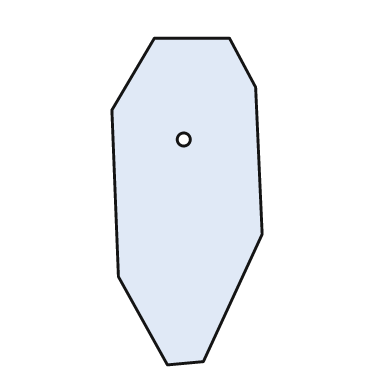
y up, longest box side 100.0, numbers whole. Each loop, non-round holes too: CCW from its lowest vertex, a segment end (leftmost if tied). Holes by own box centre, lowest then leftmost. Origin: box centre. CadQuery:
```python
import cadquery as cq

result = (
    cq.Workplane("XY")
    .moveTo(-6.0, -50.0)
    .lineTo(5.0, -49.0)
    .lineTo(23.0, -10.0)
    .lineTo(21.0, 35.0)
    .lineTo(13.0, 50.0)
    .lineTo(-10.0, 50.0)
    .lineTo(-23.0, 28.0)
    .lineTo(-21.0, -23.0)
    .close()
    .moveTo(-1.0, 19.0)
    .circle(2.0)
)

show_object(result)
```